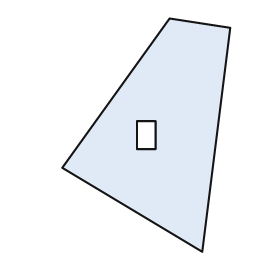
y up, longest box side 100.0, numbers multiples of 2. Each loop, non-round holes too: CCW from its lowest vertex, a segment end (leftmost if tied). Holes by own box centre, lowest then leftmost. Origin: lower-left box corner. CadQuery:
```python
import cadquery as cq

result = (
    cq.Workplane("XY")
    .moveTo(60.0, 0.0)
    .lineTo(72.0, 96.0)
    .lineTo(46.0, 100.0)
    .lineTo(0.0, 36.0)
    .close()
    .moveTo(32.0, 44.0)
    .lineTo(40.0, 44.0)
    .lineTo(40.0, 56.0)
    .lineTo(32.0, 56.0)
    .close()
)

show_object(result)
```